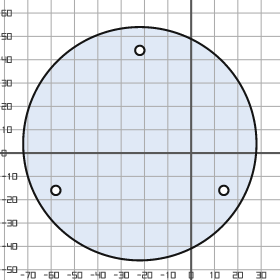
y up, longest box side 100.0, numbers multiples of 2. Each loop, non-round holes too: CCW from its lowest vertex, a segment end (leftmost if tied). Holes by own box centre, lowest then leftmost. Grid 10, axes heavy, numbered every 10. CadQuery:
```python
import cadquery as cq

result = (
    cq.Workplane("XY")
    .moveTo(-22.0, 4.0)
    .circle(50.0)
    .moveTo(-58.0, -16.0)
    .circle(2.0)
    .moveTo(14.0, -16.0)
    .circle(2.0)
    .moveTo(-22.0, 44.0)
    .circle(2.0)
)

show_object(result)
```